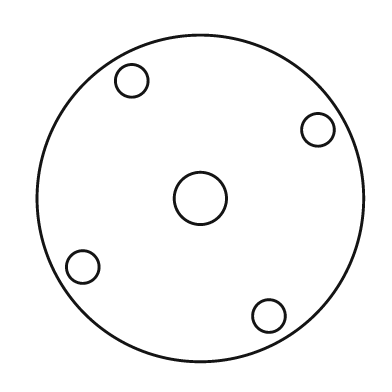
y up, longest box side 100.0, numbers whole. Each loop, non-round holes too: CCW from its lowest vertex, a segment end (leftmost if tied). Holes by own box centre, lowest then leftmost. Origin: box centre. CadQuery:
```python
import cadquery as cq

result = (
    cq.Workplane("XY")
    .moveTo(0.0, 0.0)
    .circle(50.0)
    .moveTo(21.0, -36.0)
    .circle(5.0)
    .moveTo(-36.0, -21.0)
    .circle(5.0)
    .moveTo(0.0, 0.0)
    .circle(8.0)
    .moveTo(36.0, 21.0)
    .circle(5.0)
    .moveTo(-21.0, 36.0)
    .circle(5.0)
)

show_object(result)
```